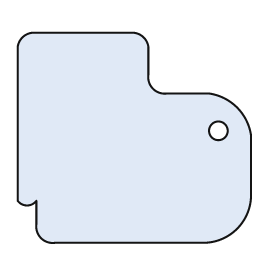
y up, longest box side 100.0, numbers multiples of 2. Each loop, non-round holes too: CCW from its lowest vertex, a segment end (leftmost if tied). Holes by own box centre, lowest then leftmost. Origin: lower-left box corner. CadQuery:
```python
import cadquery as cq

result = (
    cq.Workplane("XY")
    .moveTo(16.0, 0.0)
    .lineTo(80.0, 0.0)
    .threePointArc((94.0, 6.0), (100.0, 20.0))
    .lineTo(100.0, 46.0)
    .threePointArc((94.0, 58.0), (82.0, 64.0))
    .lineTo(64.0, 64.0)
    .threePointArc((58.0, 66.0), (56.0, 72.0))
    .lineTo(56.0, 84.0)
    .threePointArc((54.0, 88.0), (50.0, 90.0))
    .lineTo(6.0, 90.0)
    .threePointArc((2.0, 88.0), (0.0, 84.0))
    .lineTo(0.0, 18.0)
    .threePointArc((4.0, 16.0), (8.0, 18.0))
    .lineTo(8.0, 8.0)
    .threePointArc((10.0, 2.0), (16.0, 0.0))
    .close()
    .moveTo(86.0, 48.0)
    .circle(4.0)
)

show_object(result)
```